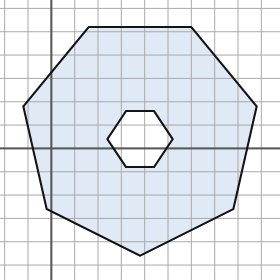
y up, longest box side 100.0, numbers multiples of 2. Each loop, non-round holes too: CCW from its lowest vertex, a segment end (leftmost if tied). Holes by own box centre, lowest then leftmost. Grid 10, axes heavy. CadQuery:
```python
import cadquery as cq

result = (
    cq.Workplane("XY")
    .moveTo(38.0, -46.0)
    .lineTo(78.0, -26.0)
    .lineTo(88.0, 18.0)
    .lineTo(60.0, 52.0)
    .lineTo(16.0, 52.0)
    .lineTo(-12.0, 18.0)
    .lineTo(-2.0, -26.0)
    .close()
    .moveTo(32.0, -8.0)
    .lineTo(44.0, -8.0)
    .lineTo(52.0, 4.0)
    .lineTo(44.0, 16.0)
    .lineTo(32.0, 16.0)
    .lineTo(24.0, 4.0)
    .close()
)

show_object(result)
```